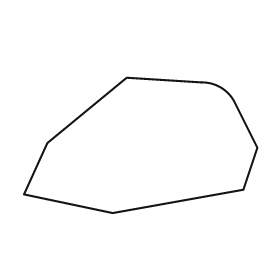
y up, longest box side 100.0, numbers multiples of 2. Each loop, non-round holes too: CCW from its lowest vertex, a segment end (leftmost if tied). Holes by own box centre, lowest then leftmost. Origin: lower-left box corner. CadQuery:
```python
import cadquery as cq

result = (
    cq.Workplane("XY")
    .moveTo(38.0, 0.0)
    .lineTo(94.0, 10.0)
    .lineTo(100.0, 28.0)
    .lineTo(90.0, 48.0)
    .threePointArc((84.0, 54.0), (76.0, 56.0))
    .lineTo(44.0, 58.0)
    .lineTo(10.0, 30.0)
    .lineTo(0.0, 8.0)
    .close()
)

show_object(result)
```